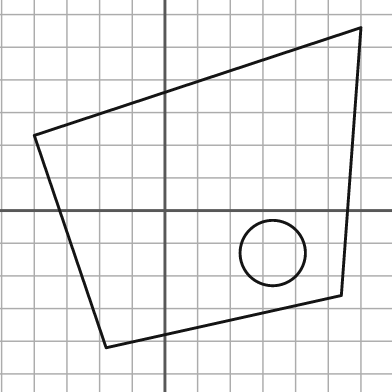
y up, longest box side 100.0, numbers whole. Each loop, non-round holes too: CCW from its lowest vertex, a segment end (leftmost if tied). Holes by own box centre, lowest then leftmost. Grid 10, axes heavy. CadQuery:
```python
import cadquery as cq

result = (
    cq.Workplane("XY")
    .moveTo(-18.0, -42.0)
    .lineTo(54.0, -26.0)
    .lineTo(60.0, 56.0)
    .lineTo(-40.0, 23.0)
    .close()
    .moveTo(33.0, -13.0)
    .circle(10.0)
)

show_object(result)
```